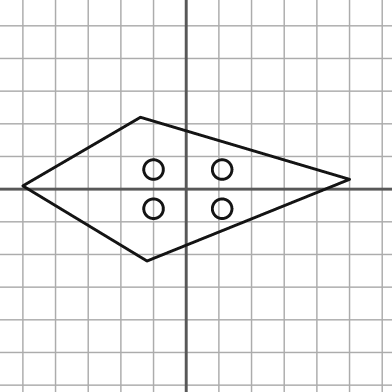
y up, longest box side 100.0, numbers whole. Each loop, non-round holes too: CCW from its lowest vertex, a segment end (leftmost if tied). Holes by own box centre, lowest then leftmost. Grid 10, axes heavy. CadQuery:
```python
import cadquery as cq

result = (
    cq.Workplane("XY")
    .moveTo(-12.0, -22.0)
    .lineTo(50.0, 3.0)
    .lineTo(-14.0, 22.0)
    .lineTo(-50.0, 1.0)
    .close()
    .moveTo(-10.0, -6.0)
    .circle(3.0)
    .moveTo(11.0, -6.0)
    .circle(3.0)
    .moveTo(-10.0, 6.0)
    .circle(3.0)
    .moveTo(11.0, 6.0)
    .circle(3.0)
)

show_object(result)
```